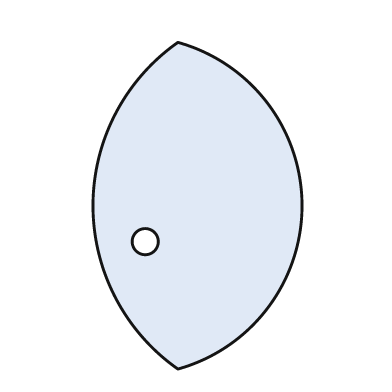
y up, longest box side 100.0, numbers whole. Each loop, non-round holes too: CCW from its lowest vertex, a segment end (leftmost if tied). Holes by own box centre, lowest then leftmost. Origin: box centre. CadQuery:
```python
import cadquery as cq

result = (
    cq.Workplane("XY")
    .moveTo(-6.0, -50.0)
    .threePointArc((32.0, 0.0), (-6.0, 50.0))
    .threePointArc((-32.0, 0.0), (-6.0, -50.0))
    .close()
    .moveTo(-16.0, -11.0)
    .circle(4.0)
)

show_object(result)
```